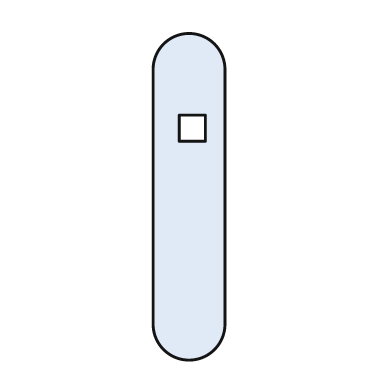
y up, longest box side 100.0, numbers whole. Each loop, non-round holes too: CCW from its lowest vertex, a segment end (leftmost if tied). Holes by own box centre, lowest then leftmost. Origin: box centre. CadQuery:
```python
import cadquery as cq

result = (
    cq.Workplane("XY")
    .moveTo(-11.0, -39.0)
    .threePointArc((0.0, -50.0), (11.0, -39.0))
    .lineTo(11.0, 39.0)
    .threePointArc((0.0, 50.0), (-11.0, 39.0))
    .close()
    .moveTo(-3.0, 17.0)
    .lineTo(5.0, 17.0)
    .lineTo(5.0, 25.0)
    .lineTo(-3.0, 25.0)
    .close()
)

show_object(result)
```